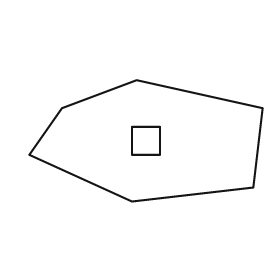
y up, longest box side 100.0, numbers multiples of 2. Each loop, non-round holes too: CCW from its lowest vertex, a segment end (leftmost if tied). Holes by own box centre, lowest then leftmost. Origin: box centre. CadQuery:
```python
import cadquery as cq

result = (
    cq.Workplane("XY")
    .moveTo(-6.0, -26.0)
    .lineTo(46.0, -20.0)
    .lineTo(50.0, 14.0)
    .lineTo(-4.0, 26.0)
    .lineTo(-36.0, 14.0)
    .lineTo(-50.0, -6.0)
    .close()
    .moveTo(-6.0, -6.0)
    .lineTo(6.0, -6.0)
    .lineTo(6.0, 6.0)
    .lineTo(-6.0, 6.0)
    .close()
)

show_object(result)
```